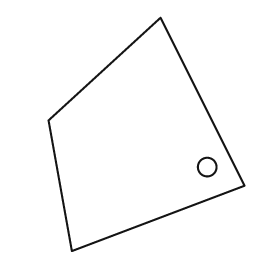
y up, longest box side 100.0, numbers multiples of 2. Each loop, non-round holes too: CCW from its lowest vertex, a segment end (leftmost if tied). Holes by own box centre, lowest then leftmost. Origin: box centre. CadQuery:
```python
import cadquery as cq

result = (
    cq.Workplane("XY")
    .moveTo(-32.0, -50.0)
    .lineTo(42.0, -22.0)
    .lineTo(6.0, 50.0)
    .lineTo(-42.0, 6.0)
    .close()
    .moveTo(26.0, -14.0)
    .circle(4.0)
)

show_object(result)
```